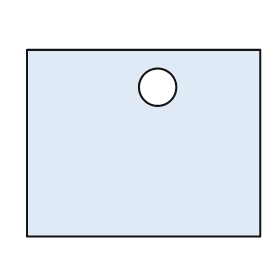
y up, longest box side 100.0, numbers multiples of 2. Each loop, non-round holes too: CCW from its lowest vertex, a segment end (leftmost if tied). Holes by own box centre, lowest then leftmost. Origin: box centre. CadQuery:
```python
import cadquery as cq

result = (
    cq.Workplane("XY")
    .moveTo(-50.0, -40.0)
    .lineTo(50.0, -40.0)
    .lineTo(50.0, 40.0)
    .lineTo(-50.0, 40.0)
    .close()
    .moveTo(6.0, 24.0)
    .circle(8.0)
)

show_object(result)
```